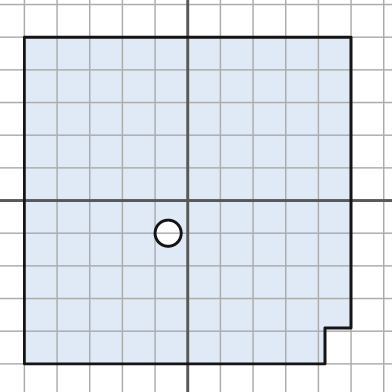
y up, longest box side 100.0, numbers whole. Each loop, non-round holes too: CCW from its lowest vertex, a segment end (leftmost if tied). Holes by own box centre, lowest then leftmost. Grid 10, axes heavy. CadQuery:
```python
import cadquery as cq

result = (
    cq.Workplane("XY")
    .moveTo(-50.0, -50.0)
    .lineTo(42.0, -50.0)
    .lineTo(42.0, -39.0)
    .lineTo(50.0, -39.0)
    .lineTo(50.0, 50.0)
    .lineTo(-50.0, 50.0)
    .close()
    .moveTo(-6.0, -10.0)
    .circle(4.0)
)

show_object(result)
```